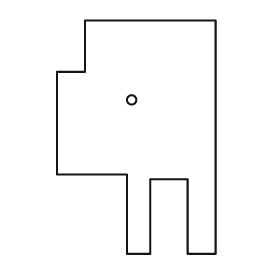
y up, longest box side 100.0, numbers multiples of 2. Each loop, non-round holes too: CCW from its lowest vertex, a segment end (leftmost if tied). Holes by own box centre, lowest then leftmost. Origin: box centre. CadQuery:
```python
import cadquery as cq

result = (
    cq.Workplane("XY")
    .moveTo(-4.0, -50.0)
    .lineTo(6.0, -50.0)
    .lineTo(6.0, -18.0)
    .lineTo(22.0, -18.0)
    .lineTo(22.0, -50.0)
    .lineTo(34.0, -50.0)
    .lineTo(34.0, 50.0)
    .lineTo(-22.0, 50.0)
    .lineTo(-22.0, 28.0)
    .lineTo(-34.0, 28.0)
    .lineTo(-34.0, -16.0)
    .lineTo(-4.0, -16.0)
    .close()
    .moveTo(-2.0, 16.0)
    .circle(2.0)
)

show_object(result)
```